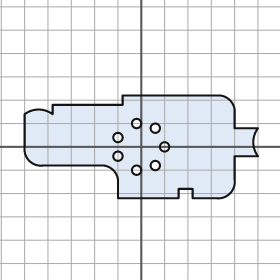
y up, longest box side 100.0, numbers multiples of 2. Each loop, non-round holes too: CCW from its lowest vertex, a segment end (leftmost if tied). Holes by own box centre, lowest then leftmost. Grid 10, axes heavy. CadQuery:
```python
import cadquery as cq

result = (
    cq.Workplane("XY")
    .moveTo(-10.0, -22.0)
    .lineTo(16.0, -22.0)
    .lineTo(16.0, -18.0)
    .lineTo(22.0, -18.0)
    .lineTo(22.0, -22.0)
    .lineTo(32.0, -22.0)
    .threePointArc((38.0, -20.0), (40.0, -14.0))
    .lineTo(40.0, -4.0)
    .lineTo(50.0, -4.0)
    .threePointArc((48.0, 2.0), (50.0, 8.0))
    .lineTo(40.0, 8.0)
    .lineTo(40.0, 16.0)
    .threePointArc((38.0, 20.0), (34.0, 22.0))
    .lineTo(-8.0, 22.0)
    .lineTo(-8.0, 18.0)
    .lineTo(-38.0, 18.0)
    .lineTo(-38.0, 14.0)
    .threePointArc((-44.0, 16.0), (-50.0, 14.0))
    .lineTo(-50.0, 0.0)
    .threePointArc((-48.0, -6.0), (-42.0, -8.0))
    .lineTo(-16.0, -8.0)
    .threePointArc((-12.0, -10.0), (-10.0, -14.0))
    .close()
    .moveTo(-2.0, -10.0)
    .circle(2.0)
    .moveTo(6.0, -8.0)
    .circle(2.0)
    .moveTo(-10.0, -4.0)
    .circle(2.0)
    .moveTo(10.0, 0.0)
    .circle(2.0)
    .moveTo(-10.0, 4.0)
    .circle(2.0)
    .moveTo(6.0, 8.0)
    .circle(2.0)
    .moveTo(-2.0, 10.0)
    .circle(2.0)
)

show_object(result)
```